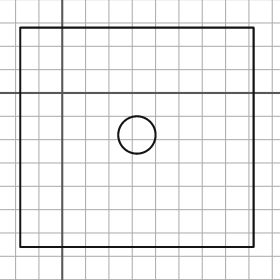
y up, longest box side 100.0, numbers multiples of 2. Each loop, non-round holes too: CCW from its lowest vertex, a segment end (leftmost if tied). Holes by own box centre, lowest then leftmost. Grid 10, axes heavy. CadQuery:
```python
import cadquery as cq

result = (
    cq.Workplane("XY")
    .moveTo(-18.0, -66.0)
    .lineTo(82.0, -66.0)
    .lineTo(82.0, 28.0)
    .lineTo(-18.0, 28.0)
    .close()
    .moveTo(32.0, -18.0)
    .circle(8.0)
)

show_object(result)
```